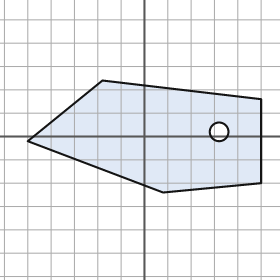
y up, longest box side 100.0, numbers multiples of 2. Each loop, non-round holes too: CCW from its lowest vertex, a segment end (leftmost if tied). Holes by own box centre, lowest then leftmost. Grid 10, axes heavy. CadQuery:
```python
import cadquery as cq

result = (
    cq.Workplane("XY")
    .moveTo(8.0, -24.0)
    .lineTo(50.0, -20.0)
    .lineTo(50.0, 16.0)
    .lineTo(-18.0, 24.0)
    .lineTo(-50.0, -2.0)
    .close()
    .moveTo(32.0, 2.0)
    .circle(4.0)
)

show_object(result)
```